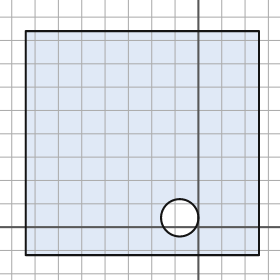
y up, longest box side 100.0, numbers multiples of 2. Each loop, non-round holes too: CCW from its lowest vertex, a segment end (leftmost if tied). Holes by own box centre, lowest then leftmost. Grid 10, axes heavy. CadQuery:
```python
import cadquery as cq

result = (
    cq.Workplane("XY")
    .moveTo(-74.0, -12.0)
    .lineTo(26.0, -12.0)
    .lineTo(26.0, 84.0)
    .lineTo(-74.0, 84.0)
    .close()
    .moveTo(-8.0, 4.0)
    .circle(8.0)
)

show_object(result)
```